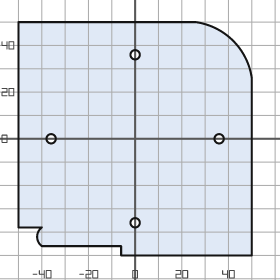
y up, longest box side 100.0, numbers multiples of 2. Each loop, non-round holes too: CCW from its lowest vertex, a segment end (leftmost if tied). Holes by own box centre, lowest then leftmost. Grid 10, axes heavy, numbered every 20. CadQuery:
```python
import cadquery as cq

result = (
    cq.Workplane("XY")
    .moveTo(-6.0, -50.0)
    .lineTo(50.0, -50.0)
    .lineTo(50.0, 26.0)
    .threePointArc((42.0, 42.0), (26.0, 50.0))
    .lineTo(-50.0, 50.0)
    .lineTo(-50.0, -38.0)
    .lineTo(-40.0, -38.0)
    .threePointArc((-42.0, -42.0), (-40.0, -46.0))
    .lineTo(-6.0, -46.0)
    .close()
    .moveTo(0.0, -36.0)
    .circle(2.0)
    .moveTo(-36.0, 0.0)
    .circle(2.0)
    .moveTo(36.0, 0.0)
    .circle(2.0)
    .moveTo(0.0, 36.0)
    .circle(2.0)
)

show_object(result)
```